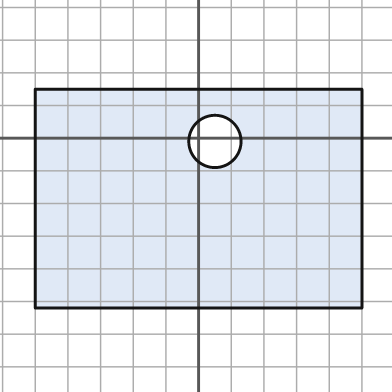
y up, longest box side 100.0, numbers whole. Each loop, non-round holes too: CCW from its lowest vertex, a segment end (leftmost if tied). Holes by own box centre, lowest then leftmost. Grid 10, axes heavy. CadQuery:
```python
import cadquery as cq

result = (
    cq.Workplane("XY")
    .moveTo(-50.0, -52.0)
    .lineTo(50.0, -52.0)
    .lineTo(50.0, 15.0)
    .lineTo(-50.0, 15.0)
    .close()
    .moveTo(5.0, -1.0)
    .circle(8.0)
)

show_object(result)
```